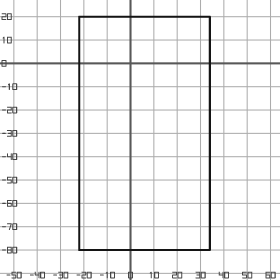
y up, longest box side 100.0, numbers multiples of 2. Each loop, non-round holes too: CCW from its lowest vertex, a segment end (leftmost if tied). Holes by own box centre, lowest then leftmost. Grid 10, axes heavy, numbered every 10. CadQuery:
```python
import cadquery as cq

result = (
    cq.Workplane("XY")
    .moveTo(-22.0, -80.0)
    .lineTo(34.0, -80.0)
    .lineTo(34.0, 20.0)
    .lineTo(-22.0, 20.0)
    .close()
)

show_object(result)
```